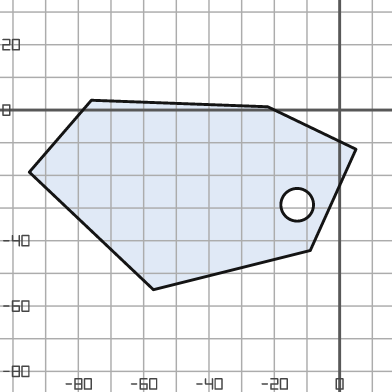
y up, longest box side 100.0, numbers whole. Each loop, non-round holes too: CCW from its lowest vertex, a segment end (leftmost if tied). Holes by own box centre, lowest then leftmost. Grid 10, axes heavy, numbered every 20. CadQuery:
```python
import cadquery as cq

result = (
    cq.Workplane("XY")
    .moveTo(-57.0, -55.0)
    .lineTo(-9.0, -43.0)
    .lineTo(5.0, -12.0)
    .lineTo(-22.0, 1.0)
    .lineTo(-76.0, 3.0)
    .lineTo(-95.0, -19.0)
    .close()
    .moveTo(-13.0, -29.0)
    .circle(5.0)
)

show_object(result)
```